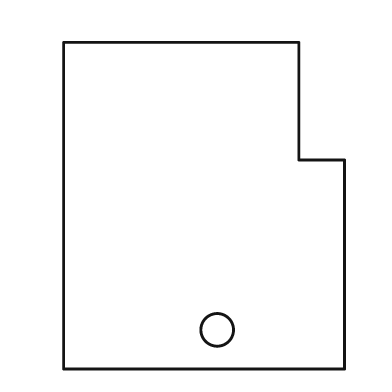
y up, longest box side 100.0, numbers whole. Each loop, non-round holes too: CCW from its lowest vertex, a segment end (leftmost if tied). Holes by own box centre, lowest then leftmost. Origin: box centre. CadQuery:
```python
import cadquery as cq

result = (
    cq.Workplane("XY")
    .moveTo(-43.0, -50.0)
    .lineTo(43.0, -50.0)
    .lineTo(43.0, 14.0)
    .lineTo(29.0, 14.0)
    .lineTo(29.0, 50.0)
    .lineTo(-43.0, 50.0)
    .close()
    .moveTo(4.0, -38.0)
    .circle(5.0)
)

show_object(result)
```